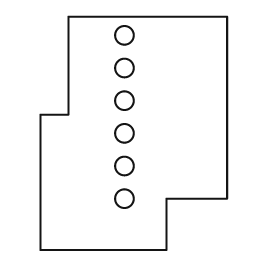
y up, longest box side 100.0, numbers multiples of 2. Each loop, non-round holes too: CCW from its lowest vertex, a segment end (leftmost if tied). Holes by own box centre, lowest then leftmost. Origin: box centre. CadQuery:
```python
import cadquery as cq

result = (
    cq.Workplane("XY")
    .moveTo(-40.0, -50.0)
    .lineTo(14.0, -50.0)
    .lineTo(14.0, -28.0)
    .lineTo(40.0, -28.0)
    .lineTo(40.0, 50.0)
    .lineTo(-28.0, 50.0)
    .lineTo(-28.0, 8.0)
    .lineTo(-40.0, 8.0)
    .close()
    .moveTo(-4.0, -28.0)
    .circle(4.0)
    .moveTo(-4.0, -14.0)
    .circle(4.0)
    .moveTo(-4.0, 0.0)
    .circle(4.0)
    .moveTo(-4.0, 14.0)
    .circle(4.0)
    .moveTo(-4.0, 28.0)
    .circle(4.0)
    .moveTo(-4.0, 42.0)
    .circle(4.0)
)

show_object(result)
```